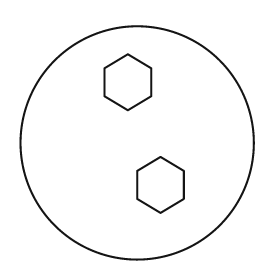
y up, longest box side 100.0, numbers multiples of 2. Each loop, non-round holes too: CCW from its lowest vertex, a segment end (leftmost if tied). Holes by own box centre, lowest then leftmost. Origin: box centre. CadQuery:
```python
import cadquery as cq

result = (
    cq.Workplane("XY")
    .moveTo(0.0, 0.0)
    .circle(50.0)
    .moveTo(10.0, -30.0)
    .lineTo(20.0, -24.0)
    .lineTo(20.0, -12.0)
    .lineTo(10.0, -6.0)
    .lineTo(0.0, -12.0)
    .lineTo(0.0, -24.0)
    .close()
    .moveTo(-4.0, 14.0)
    .lineTo(6.0, 20.0)
    .lineTo(6.0, 32.0)
    .lineTo(-4.0, 38.0)
    .lineTo(-14.0, 32.0)
    .lineTo(-14.0, 20.0)
    .close()
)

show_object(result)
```